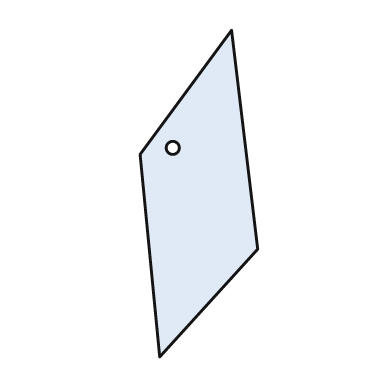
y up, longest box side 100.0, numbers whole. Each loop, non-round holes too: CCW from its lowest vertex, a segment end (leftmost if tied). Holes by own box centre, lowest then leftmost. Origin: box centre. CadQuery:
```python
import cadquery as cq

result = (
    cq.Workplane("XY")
    .moveTo(-12.0, -50.0)
    .lineTo(18.0, -17.0)
    .lineTo(10.0, 50.0)
    .lineTo(-18.0, 12.0)
    .close()
    .moveTo(-8.0, 14.0)
    .circle(2.0)
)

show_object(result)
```